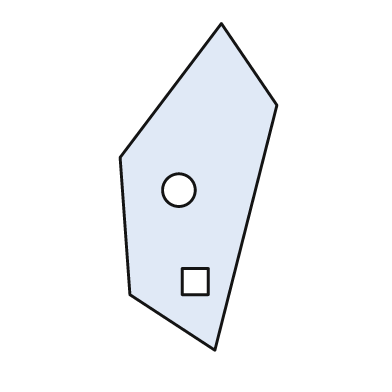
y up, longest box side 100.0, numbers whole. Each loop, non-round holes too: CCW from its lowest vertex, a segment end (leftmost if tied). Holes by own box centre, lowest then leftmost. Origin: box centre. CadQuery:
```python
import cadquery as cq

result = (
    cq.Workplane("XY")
    .moveTo(5.0, -50.0)
    .lineTo(24.0, 25.0)
    .lineTo(7.0, 50.0)
    .lineTo(-24.0, 9.0)
    .lineTo(-21.0, -33.0)
    .close()
    .moveTo(-5.0, -33.0)
    .lineTo(3.0, -33.0)
    .lineTo(3.0, -25.0)
    .lineTo(-5.0, -25.0)
    .close()
    .moveTo(-6.0, -1.0)
    .circle(5.0)
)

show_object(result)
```